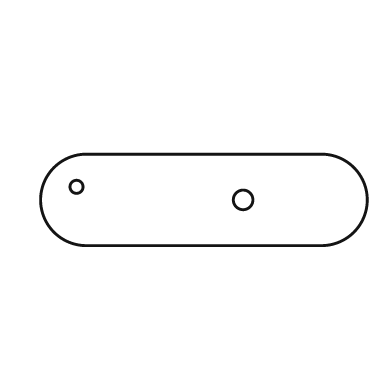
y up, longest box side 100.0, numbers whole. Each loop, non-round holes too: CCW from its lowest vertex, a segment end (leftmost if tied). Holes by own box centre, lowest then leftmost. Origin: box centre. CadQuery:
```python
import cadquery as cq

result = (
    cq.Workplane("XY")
    .moveTo(-36.0, -14.0)
    .lineTo(36.0, -14.0)
    .threePointArc((50.0, 0.0), (36.0, 14.0))
    .lineTo(-36.0, 14.0)
    .threePointArc((-50.0, 0.0), (-36.0, -14.0))
    .close()
    .moveTo(12.0, 0.0)
    .circle(3.0)
    .moveTo(-39.0, 4.0)
    .circle(2.0)
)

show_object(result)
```